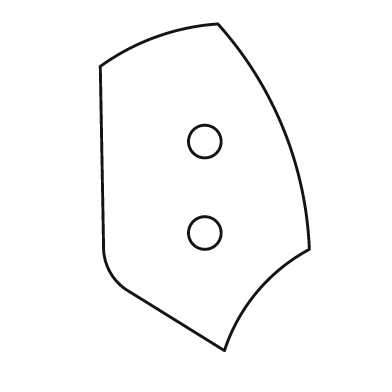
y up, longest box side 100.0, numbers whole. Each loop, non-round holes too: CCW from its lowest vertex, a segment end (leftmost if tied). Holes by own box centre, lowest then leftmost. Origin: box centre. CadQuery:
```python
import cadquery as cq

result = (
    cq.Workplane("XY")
    .moveTo(6.0, -50.0)
    .threePointArc((16.0, -32.0), (32.0, -19.0))
    .threePointArc((24.0, 18.0), (4.0, 50.0))
    .threePointArc((-15.0, 46.0), (-32.0, 37.0))
    .lineTo(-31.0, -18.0)
    .threePointArc((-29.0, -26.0), (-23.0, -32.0))
    .close()
    .moveTo(0.0, -14.0)
    .circle(5.0)
    .moveTo(0.0, 14.0)
    .circle(5.0)
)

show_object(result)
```